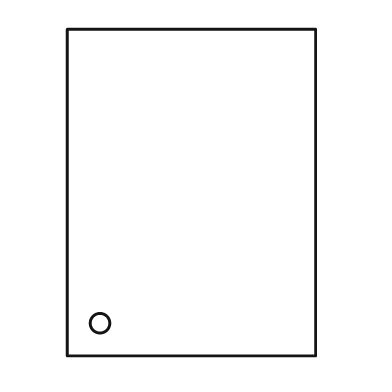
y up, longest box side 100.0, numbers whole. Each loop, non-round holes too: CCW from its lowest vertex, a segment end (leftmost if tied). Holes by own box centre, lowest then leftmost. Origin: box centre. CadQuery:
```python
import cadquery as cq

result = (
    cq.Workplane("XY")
    .moveTo(-38.0, -50.0)
    .lineTo(38.0, -50.0)
    .lineTo(38.0, 50.0)
    .lineTo(-38.0, 50.0)
    .close()
    .moveTo(-28.0, -40.0)
    .circle(3.0)
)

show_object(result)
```